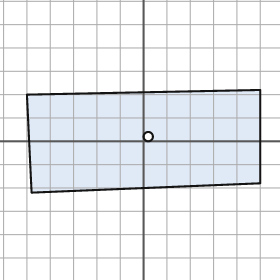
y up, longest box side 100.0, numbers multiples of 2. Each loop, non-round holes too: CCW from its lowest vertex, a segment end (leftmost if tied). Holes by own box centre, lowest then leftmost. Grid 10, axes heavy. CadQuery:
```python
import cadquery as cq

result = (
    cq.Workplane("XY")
    .moveTo(-48.0, -22.0)
    .lineTo(50.0, -18.0)
    .lineTo(50.0, 22.0)
    .lineTo(-50.0, 20.0)
    .close()
    .moveTo(2.0, 2.0)
    .circle(2.0)
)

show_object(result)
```